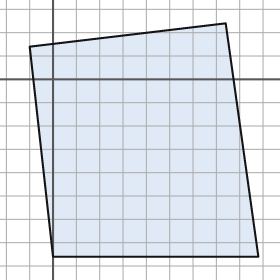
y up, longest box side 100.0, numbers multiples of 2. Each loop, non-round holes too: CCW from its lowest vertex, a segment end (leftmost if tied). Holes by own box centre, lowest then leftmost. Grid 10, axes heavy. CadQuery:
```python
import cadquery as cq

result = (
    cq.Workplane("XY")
    .moveTo(0.0, -76.0)
    .lineTo(88.0, -76.0)
    .lineTo(74.0, 24.0)
    .lineTo(-10.0, 14.0)
    .close()
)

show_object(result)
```